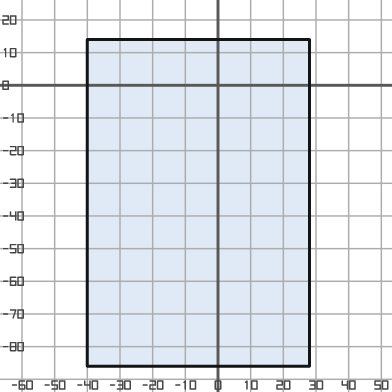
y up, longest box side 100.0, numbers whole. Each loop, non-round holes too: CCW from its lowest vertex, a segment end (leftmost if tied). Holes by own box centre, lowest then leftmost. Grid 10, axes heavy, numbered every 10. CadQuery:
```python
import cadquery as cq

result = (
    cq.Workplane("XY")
    .moveTo(-40.0, -86.0)
    .lineTo(28.0, -86.0)
    .lineTo(28.0, 14.0)
    .lineTo(-40.0, 14.0)
    .close()
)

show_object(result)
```